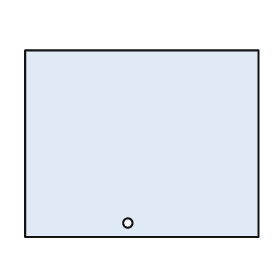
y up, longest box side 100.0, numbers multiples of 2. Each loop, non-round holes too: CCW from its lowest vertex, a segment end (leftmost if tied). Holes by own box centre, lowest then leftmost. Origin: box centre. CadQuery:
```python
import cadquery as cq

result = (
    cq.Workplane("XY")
    .moveTo(-50.0, -40.0)
    .lineTo(50.0, -40.0)
    .lineTo(50.0, 40.0)
    .lineTo(-50.0, 40.0)
    .close()
    .moveTo(-6.0, -34.0)
    .circle(2.0)
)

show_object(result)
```